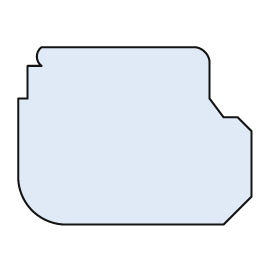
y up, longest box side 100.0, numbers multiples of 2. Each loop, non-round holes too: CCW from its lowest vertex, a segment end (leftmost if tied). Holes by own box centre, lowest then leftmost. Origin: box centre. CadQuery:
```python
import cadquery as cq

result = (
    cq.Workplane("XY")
    .moveTo(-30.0, -38.0)
    .lineTo(38.0, -38.0)
    .lineTo(50.0, -26.0)
    .lineTo(50.0, 2.0)
    .lineTo(44.0, 8.0)
    .lineTo(38.0, 8.0)
    .lineTo(32.0, 16.0)
    .lineTo(32.0, 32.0)
    .threePointArc((30.0, 36.0), (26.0, 38.0))
    .lineTo(-40.0, 38.0)
    .threePointArc((-42.0, 34.0), (-40.0, 30.0))
    .lineTo(-46.0, 30.0)
    .lineTo(-46.0, 16.0)
    .lineTo(-50.0, 16.0)
    .lineTo(-50.0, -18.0)
    .threePointArc((-44.0, -32.0), (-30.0, -38.0))
    .close()
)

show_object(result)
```